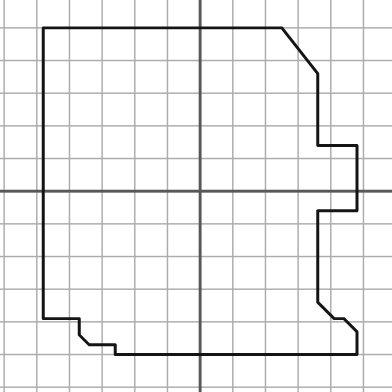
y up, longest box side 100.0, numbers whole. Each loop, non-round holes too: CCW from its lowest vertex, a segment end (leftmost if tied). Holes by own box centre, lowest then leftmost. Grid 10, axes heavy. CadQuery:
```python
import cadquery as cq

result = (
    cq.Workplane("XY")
    .moveTo(-26.0, -50.0)
    .lineTo(48.0, -50.0)
    .lineTo(48.0, -43.0)
    .lineTo(44.0, -39.0)
    .lineTo(41.0, -39.0)
    .lineTo(36.0, -34.0)
    .lineTo(36.0, -6.0)
    .lineTo(48.0, -6.0)
    .lineTo(48.0, 14.0)
    .lineTo(36.0, 14.0)
    .lineTo(36.0, 36.0)
    .lineTo(25.0, 50.0)
    .lineTo(-48.0, 50.0)
    .lineTo(-48.0, -39.0)
    .lineTo(-37.0, -39.0)
    .lineTo(-37.0, -44.0)
    .lineTo(-34.0, -47.0)
    .lineTo(-26.0, -47.0)
    .close()
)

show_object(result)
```